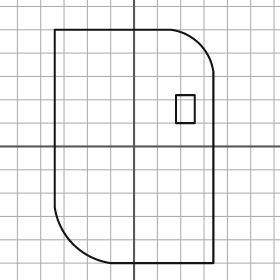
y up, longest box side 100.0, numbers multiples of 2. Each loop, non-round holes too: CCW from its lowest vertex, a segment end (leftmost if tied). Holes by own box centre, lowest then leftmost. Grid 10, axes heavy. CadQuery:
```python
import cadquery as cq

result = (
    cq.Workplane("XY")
    .moveTo(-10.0, -50.0)
    .lineTo(34.0, -50.0)
    .lineTo(34.0, 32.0)
    .threePointArc((28.0, 44.0), (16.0, 50.0))
    .lineTo(-34.0, 50.0)
    .lineTo(-34.0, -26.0)
    .threePointArc((-26.0, -42.0), (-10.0, -50.0))
    .close()
    .moveTo(18.0, 10.0)
    .lineTo(26.0, 10.0)
    .lineTo(26.0, 22.0)
    .lineTo(18.0, 22.0)
    .close()
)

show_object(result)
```